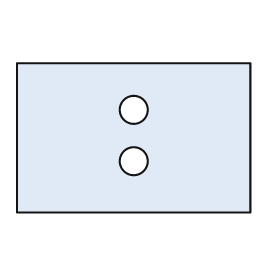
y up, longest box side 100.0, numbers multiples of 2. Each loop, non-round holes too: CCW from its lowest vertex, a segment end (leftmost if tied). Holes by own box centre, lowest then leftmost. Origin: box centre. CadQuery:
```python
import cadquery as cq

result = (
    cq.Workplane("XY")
    .moveTo(-50.0, -32.0)
    .lineTo(50.0, -32.0)
    .lineTo(50.0, 32.0)
    .lineTo(-50.0, 32.0)
    .close()
    .moveTo(0.0, -10.0)
    .circle(6.0)
    .moveTo(0.0, 12.0)
    .circle(6.0)
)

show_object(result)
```